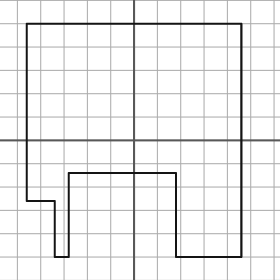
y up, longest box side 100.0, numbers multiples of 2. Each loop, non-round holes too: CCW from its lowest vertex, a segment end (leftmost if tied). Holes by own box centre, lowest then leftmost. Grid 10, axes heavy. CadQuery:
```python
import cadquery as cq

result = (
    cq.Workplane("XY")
    .moveTo(-34.0, -50.0)
    .lineTo(-28.0, -50.0)
    .lineTo(-28.0, -14.0)
    .lineTo(18.0, -14.0)
    .lineTo(18.0, -50.0)
    .lineTo(46.0, -50.0)
    .lineTo(46.0, 50.0)
    .lineTo(-46.0, 50.0)
    .lineTo(-46.0, -26.0)
    .lineTo(-34.0, -26.0)
    .close()
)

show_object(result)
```